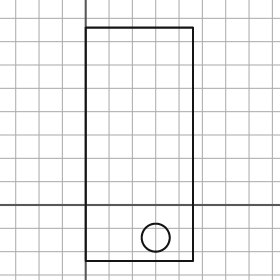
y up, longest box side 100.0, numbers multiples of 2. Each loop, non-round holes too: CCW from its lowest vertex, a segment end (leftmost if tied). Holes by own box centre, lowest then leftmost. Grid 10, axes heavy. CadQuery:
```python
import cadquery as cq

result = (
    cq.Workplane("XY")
    .moveTo(0.0, -24.0)
    .lineTo(46.0, -24.0)
    .lineTo(46.0, 76.0)
    .lineTo(0.0, 76.0)
    .close()
    .moveTo(30.0, -14.0)
    .circle(6.0)
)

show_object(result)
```